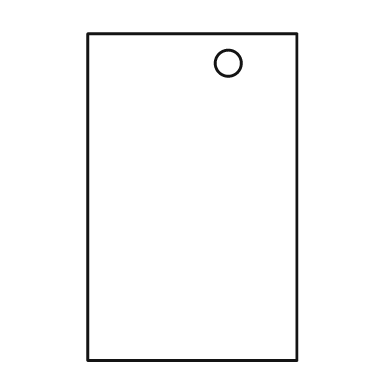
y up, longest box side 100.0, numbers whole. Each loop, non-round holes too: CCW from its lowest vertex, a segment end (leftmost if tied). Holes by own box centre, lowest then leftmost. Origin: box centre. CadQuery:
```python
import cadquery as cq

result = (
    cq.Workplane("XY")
    .moveTo(-32.0, -50.0)
    .lineTo(32.0, -50.0)
    .lineTo(32.0, 50.0)
    .lineTo(-32.0, 50.0)
    .close()
    .moveTo(11.0, 41.0)
    .circle(4.0)
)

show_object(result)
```